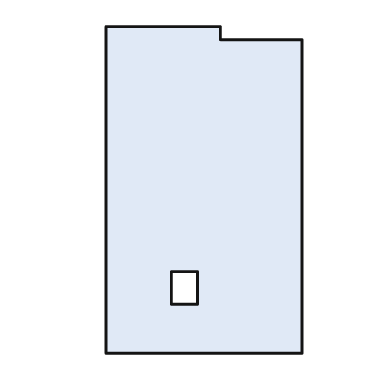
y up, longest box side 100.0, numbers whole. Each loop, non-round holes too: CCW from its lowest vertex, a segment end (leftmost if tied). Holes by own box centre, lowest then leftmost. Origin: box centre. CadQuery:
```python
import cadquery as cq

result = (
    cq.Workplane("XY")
    .moveTo(-30.0, -50.0)
    .lineTo(30.0, -50.0)
    .lineTo(30.0, 46.0)
    .lineTo(5.0, 46.0)
    .lineTo(5.0, 50.0)
    .lineTo(-30.0, 50.0)
    .close()
    .moveTo(-10.0, -35.0)
    .lineTo(-2.0, -35.0)
    .lineTo(-2.0, -25.0)
    .lineTo(-10.0, -25.0)
    .close()
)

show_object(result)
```